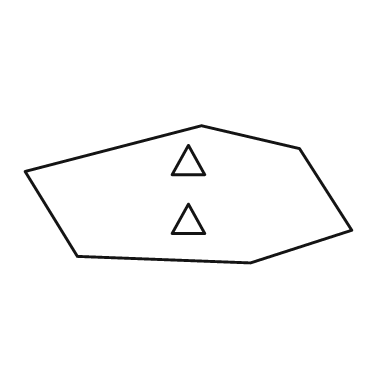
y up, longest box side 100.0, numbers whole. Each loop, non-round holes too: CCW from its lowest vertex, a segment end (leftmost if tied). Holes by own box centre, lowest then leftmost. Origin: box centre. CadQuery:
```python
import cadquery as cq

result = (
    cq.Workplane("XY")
    .moveTo(19.0, -21.0)
    .lineTo(50.0, -11.0)
    .lineTo(34.0, 14.0)
    .lineTo(4.0, 21.0)
    .lineTo(-50.0, 7.0)
    .lineTo(-34.0, -19.0)
    .close()
    .moveTo(-5.0, -12.0)
    .lineTo(5.0, -12.0)
    .lineTo(0.0, -3.0)
    .close()
    .moveTo(-5.0, 6.0)
    .lineTo(5.0, 6.0)
    .lineTo(0.0, 15.0)
    .close()
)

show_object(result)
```